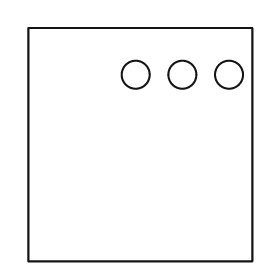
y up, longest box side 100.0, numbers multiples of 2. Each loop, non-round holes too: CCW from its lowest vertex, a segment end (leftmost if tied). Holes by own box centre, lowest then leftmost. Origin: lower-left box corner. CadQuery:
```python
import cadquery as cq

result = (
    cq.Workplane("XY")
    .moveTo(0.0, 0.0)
    .lineTo(96.0, 0.0)
    .lineTo(96.0, 100.0)
    .lineTo(0.0, 100.0)
    .close()
    .moveTo(46.0, 80.0)
    .circle(6.0)
    .moveTo(66.0, 80.0)
    .circle(6.0)
    .moveTo(86.0, 80.0)
    .circle(6.0)
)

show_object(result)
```